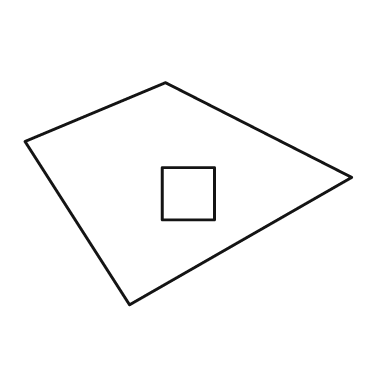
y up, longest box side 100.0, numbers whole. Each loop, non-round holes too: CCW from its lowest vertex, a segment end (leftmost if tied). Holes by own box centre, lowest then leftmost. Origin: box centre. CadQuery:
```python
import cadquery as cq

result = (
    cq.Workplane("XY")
    .moveTo(-18.0, -34.0)
    .lineTo(50.0, 5.0)
    .lineTo(-7.0, 34.0)
    .lineTo(-50.0, 16.0)
    .close()
    .moveTo(-8.0, -8.0)
    .lineTo(8.0, -8.0)
    .lineTo(8.0, 8.0)
    .lineTo(-8.0, 8.0)
    .close()
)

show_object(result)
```